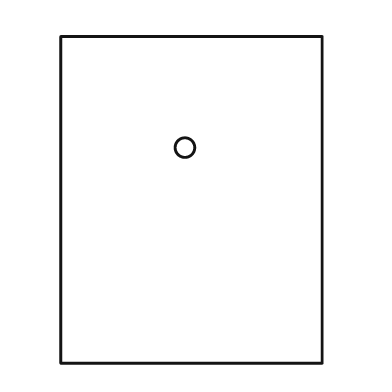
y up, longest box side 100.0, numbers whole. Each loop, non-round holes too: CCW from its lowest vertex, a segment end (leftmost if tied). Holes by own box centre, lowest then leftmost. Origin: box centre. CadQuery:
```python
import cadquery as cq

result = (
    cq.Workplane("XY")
    .moveTo(-40.0, -50.0)
    .lineTo(40.0, -50.0)
    .lineTo(40.0, 50.0)
    .lineTo(-40.0, 50.0)
    .close()
    .moveTo(-2.0, 16.0)
    .circle(3.0)
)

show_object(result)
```